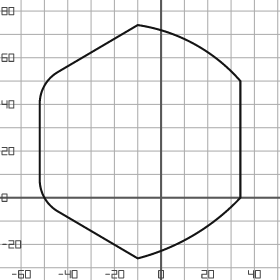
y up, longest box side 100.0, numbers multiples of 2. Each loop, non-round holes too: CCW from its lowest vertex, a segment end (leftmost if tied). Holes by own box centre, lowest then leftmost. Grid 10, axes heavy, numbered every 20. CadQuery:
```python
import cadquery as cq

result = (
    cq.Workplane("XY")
    .moveTo(-10.0, -26.0)
    .threePointArc((14.0, -16.0), (34.0, 0.0))
    .lineTo(34.0, 50.0)
    .threePointArc((14.0, 66.0), (-10.0, 74.0))
    .lineTo(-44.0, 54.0)
    .threePointArc((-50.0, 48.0), (-52.0, 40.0))
    .lineTo(-52.0, 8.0)
    .threePointArc((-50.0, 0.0), (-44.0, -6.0))
    .close()
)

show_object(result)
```